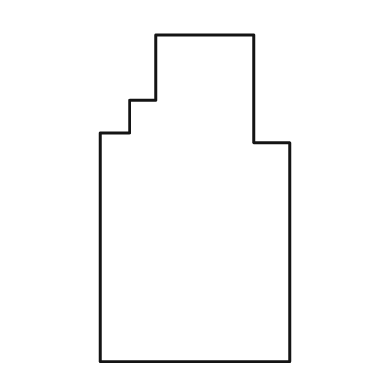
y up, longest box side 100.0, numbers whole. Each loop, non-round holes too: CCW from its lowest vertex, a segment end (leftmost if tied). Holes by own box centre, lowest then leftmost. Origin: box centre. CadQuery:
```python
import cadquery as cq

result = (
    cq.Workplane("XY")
    .moveTo(-29.0, -50.0)
    .lineTo(29.0, -50.0)
    .lineTo(29.0, 17.0)
    .lineTo(18.0, 17.0)
    .lineTo(18.0, 50.0)
    .lineTo(-12.0, 50.0)
    .lineTo(-12.0, 30.0)
    .lineTo(-20.0, 30.0)
    .lineTo(-20.0, 20.0)
    .lineTo(-29.0, 20.0)
    .close()
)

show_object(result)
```